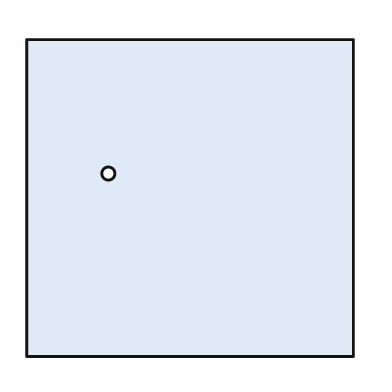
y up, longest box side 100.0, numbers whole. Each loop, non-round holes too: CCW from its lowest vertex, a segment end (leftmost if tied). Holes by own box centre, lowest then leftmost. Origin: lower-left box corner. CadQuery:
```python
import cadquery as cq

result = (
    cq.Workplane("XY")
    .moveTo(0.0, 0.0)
    .lineTo(100.0, 0.0)
    .lineTo(100.0, 97.0)
    .lineTo(0.0, 97.0)
    .close()
    .moveTo(25.0, 56.0)
    .circle(2.0)
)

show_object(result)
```